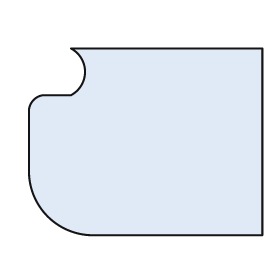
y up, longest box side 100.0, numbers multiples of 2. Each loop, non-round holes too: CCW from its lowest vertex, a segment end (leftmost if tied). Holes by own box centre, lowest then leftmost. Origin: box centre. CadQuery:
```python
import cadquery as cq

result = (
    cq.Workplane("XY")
    .moveTo(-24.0, -40.0)
    .lineTo(50.0, -40.0)
    .lineTo(50.0, 40.0)
    .lineTo(-32.0, 40.0)
    .threePointArc((-26.0, 30.0), (-32.0, 20.0))
    .lineTo(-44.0, 20.0)
    .threePointArc((-48.0, 18.0), (-50.0, 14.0))
    .lineTo(-50.0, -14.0)
    .threePointArc((-42.0, -32.0), (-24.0, -40.0))
    .close()
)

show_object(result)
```